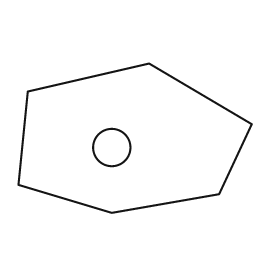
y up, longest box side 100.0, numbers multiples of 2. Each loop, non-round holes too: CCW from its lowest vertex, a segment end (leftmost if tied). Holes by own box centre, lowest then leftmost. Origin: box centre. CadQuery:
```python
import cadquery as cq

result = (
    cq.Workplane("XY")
    .moveTo(-10.0, -32.0)
    .lineTo(36.0, -24.0)
    .lineTo(50.0, 6.0)
    .lineTo(6.0, 32.0)
    .lineTo(-46.0, 20.0)
    .lineTo(-50.0, -20.0)
    .close()
    .moveTo(-10.0, -4.0)
    .circle(8.0)
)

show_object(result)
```